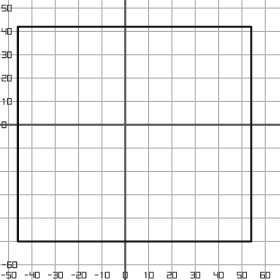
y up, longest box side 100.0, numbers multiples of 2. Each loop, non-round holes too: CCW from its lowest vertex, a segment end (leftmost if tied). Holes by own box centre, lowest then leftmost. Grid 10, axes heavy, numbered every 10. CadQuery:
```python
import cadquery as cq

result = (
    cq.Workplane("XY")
    .moveTo(-46.0, -50.0)
    .lineTo(54.0, -50.0)
    .lineTo(54.0, 42.0)
    .lineTo(-46.0, 42.0)
    .close()
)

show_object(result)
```